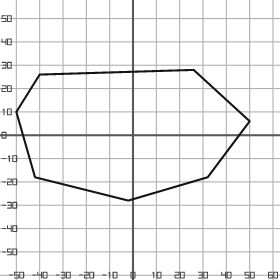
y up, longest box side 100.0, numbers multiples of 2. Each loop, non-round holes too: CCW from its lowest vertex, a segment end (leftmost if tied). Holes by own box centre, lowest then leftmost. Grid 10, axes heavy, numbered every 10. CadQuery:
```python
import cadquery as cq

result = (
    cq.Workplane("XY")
    .moveTo(-2.0, -28.0)
    .lineTo(32.0, -18.0)
    .lineTo(50.0, 6.0)
    .lineTo(26.0, 28.0)
    .lineTo(-40.0, 26.0)
    .lineTo(-50.0, 10.0)
    .lineTo(-42.0, -18.0)
    .close()
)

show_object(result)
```